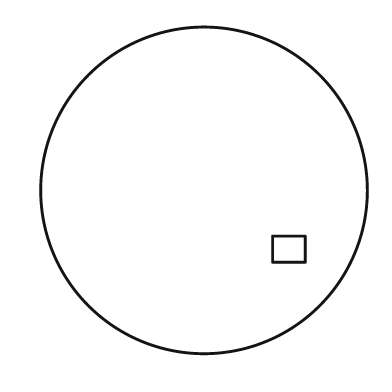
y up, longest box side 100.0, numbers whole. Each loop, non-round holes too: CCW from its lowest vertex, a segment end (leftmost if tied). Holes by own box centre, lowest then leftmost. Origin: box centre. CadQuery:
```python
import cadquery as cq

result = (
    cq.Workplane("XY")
    .moveTo(0.0, 0.0)
    .circle(50.0)
    .moveTo(21.0, -22.0)
    .lineTo(31.0, -22.0)
    .lineTo(31.0, -14.0)
    .lineTo(21.0, -14.0)
    .close()
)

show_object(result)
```